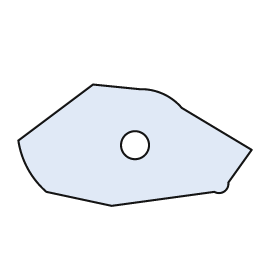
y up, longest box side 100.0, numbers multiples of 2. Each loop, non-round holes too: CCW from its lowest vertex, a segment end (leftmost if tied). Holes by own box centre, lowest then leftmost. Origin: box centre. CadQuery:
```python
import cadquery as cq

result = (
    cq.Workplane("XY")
    .moveTo(-10.0, -26.0)
    .lineTo(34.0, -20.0)
    .threePointArc((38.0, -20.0), (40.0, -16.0))
    .lineTo(50.0, -2.0)
    .lineTo(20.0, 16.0)
    .threePointArc((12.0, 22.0), (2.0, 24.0))
    .lineTo(-18.0, 26.0)
    .lineTo(-50.0, 2.0)
    .threePointArc((-46.0, -10.0), (-38.0, -20.0))
    .close()
    .moveTo(0.0, 0.0)
    .circle(6.0)
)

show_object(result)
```